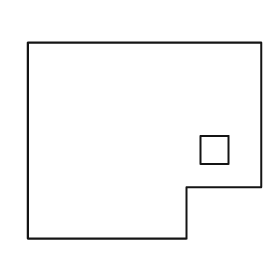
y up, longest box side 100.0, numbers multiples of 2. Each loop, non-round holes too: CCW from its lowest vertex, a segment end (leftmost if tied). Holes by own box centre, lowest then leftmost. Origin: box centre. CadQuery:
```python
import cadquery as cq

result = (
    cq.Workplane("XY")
    .moveTo(-50.0, -42.0)
    .lineTo(18.0, -42.0)
    .lineTo(18.0, -20.0)
    .lineTo(50.0, -20.0)
    .lineTo(50.0, 42.0)
    .lineTo(-50.0, 42.0)
    .close()
    .moveTo(24.0, -10.0)
    .lineTo(36.0, -10.0)
    .lineTo(36.0, 2.0)
    .lineTo(24.0, 2.0)
    .close()
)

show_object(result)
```